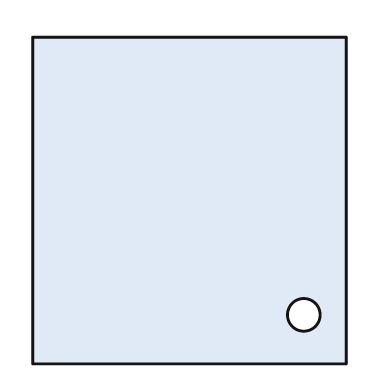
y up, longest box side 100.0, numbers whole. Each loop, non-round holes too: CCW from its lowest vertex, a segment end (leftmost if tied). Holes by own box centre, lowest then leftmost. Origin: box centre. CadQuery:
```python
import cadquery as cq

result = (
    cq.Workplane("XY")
    .moveTo(-48.0, -50.0)
    .lineTo(48.0, -50.0)
    .lineTo(48.0, 50.0)
    .lineTo(-48.0, 50.0)
    .close()
    .moveTo(35.0, -35.0)
    .circle(5.0)
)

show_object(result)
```